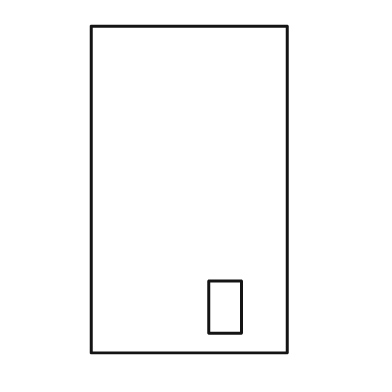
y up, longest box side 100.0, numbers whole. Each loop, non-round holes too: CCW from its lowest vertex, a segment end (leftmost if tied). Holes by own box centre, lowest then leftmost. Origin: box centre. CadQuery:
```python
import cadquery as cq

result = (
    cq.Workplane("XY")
    .moveTo(-30.0, -50.0)
    .lineTo(30.0, -50.0)
    .lineTo(30.0, 50.0)
    .lineTo(-30.0, 50.0)
    .close()
    .moveTo(6.0, -44.0)
    .lineTo(16.0, -44.0)
    .lineTo(16.0, -28.0)
    .lineTo(6.0, -28.0)
    .close()
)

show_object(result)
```